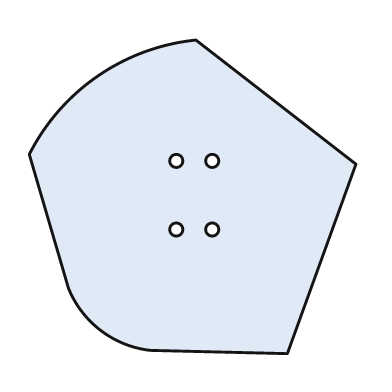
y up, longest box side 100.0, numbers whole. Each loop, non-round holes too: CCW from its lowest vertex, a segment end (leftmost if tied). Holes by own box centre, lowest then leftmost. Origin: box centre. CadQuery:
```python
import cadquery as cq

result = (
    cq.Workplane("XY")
    .moveTo(29.0, -48.0)
    .lineTo(50.0, 10.0)
    .lineTo(1.0, 48.0)
    .threePointArc((-29.0, 37.0), (-50.0, 13.0))
    .lineTo(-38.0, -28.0)
    .threePointArc((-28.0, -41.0), (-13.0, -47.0))
    .close()
    .moveTo(-5.0, -10.0)
    .circle(2.0)
    .moveTo(6.0, -10.0)
    .circle(2.0)
    .moveTo(-5.0, 11.0)
    .circle(2.0)
    .moveTo(6.0, 11.0)
    .circle(2.0)
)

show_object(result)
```